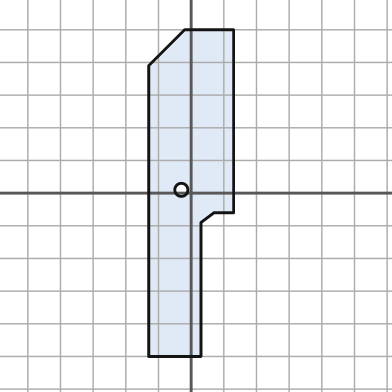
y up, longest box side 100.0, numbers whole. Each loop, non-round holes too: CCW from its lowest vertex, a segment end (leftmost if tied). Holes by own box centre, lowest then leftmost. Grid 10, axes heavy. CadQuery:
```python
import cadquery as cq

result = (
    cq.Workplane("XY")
    .moveTo(-13.0, -50.0)
    .lineTo(3.0, -50.0)
    .lineTo(3.0, -9.0)
    .lineTo(7.0, -6.0)
    .lineTo(13.0, -6.0)
    .lineTo(13.0, 50.0)
    .lineTo(-2.0, 50.0)
    .lineTo(-13.0, 39.0)
    .close()
    .moveTo(-3.0, 1.0)
    .circle(2.0)
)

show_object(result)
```